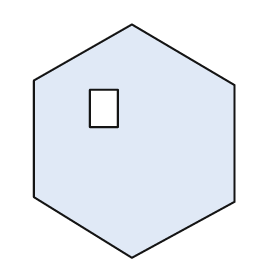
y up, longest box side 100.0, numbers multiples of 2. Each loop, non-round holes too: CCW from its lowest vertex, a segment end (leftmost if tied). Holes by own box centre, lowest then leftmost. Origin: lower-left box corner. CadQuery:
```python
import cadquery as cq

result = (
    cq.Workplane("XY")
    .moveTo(42.0, 0.0)
    .lineTo(86.0, 24.0)
    .lineTo(86.0, 74.0)
    .lineTo(42.0, 100.0)
    .lineTo(0.0, 76.0)
    .lineTo(0.0, 26.0)
    .close()
    .moveTo(24.0, 56.0)
    .lineTo(36.0, 56.0)
    .lineTo(36.0, 72.0)
    .lineTo(24.0, 72.0)
    .close()
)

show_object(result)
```